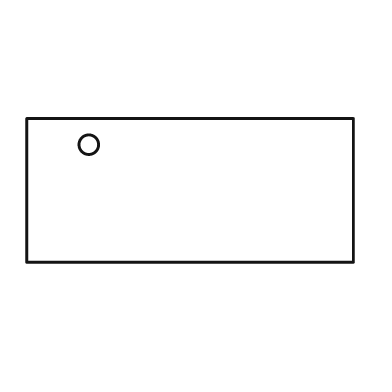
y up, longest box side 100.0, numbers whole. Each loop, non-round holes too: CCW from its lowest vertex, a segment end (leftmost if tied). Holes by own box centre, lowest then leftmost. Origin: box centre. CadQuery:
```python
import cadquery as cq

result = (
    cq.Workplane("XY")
    .moveTo(-50.0, -22.0)
    .lineTo(50.0, -22.0)
    .lineTo(50.0, 22.0)
    .lineTo(-50.0, 22.0)
    .close()
    .moveTo(-31.0, 14.0)
    .circle(3.0)
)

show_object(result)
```